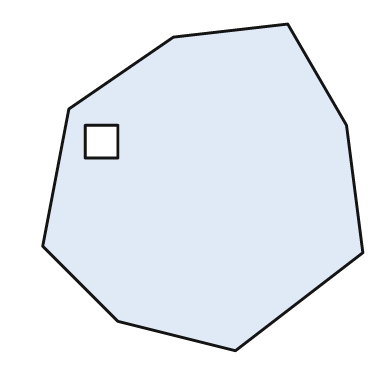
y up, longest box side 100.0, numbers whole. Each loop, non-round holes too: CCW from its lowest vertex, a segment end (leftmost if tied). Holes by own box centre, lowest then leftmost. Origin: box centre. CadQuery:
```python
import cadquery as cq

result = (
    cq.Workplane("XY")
    .moveTo(10.0, -50.0)
    .lineTo(49.0, -20.0)
    .lineTo(44.0, 19.0)
    .lineTo(26.0, 50.0)
    .lineTo(-9.0, 46.0)
    .lineTo(-41.0, 24.0)
    .lineTo(-49.0, -18.0)
    .lineTo(-26.0, -41.0)
    .close()
    .moveTo(-36.0, 9.0)
    .lineTo(-26.0, 9.0)
    .lineTo(-26.0, 19.0)
    .lineTo(-36.0, 19.0)
    .close()
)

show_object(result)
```